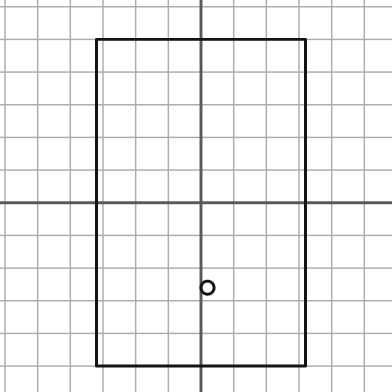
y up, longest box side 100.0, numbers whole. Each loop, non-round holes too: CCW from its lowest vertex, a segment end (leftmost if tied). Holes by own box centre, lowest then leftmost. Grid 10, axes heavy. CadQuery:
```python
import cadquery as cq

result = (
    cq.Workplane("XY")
    .moveTo(-32.0, -50.0)
    .lineTo(32.0, -50.0)
    .lineTo(32.0, 50.0)
    .lineTo(-32.0, 50.0)
    .close()
    .moveTo(2.0, -26.0)
    .circle(2.0)
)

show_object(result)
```